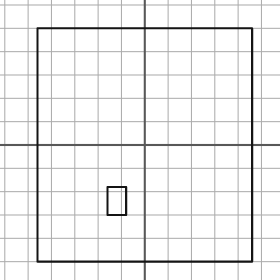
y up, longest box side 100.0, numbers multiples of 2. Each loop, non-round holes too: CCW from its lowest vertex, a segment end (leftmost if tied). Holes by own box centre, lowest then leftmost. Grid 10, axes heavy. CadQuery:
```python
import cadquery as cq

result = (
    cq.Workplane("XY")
    .moveTo(-46.0, -50.0)
    .lineTo(46.0, -50.0)
    .lineTo(46.0, 50.0)
    .lineTo(-46.0, 50.0)
    .close()
    .moveTo(-16.0, -30.0)
    .lineTo(-8.0, -30.0)
    .lineTo(-8.0, -18.0)
    .lineTo(-16.0, -18.0)
    .close()
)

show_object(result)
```